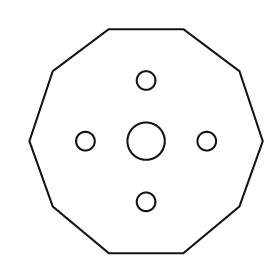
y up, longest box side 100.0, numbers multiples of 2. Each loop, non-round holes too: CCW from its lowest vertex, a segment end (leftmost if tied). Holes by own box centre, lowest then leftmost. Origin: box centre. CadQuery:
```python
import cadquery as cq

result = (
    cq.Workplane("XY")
    .moveTo(-16.0, -48.0)
    .lineTo(16.0, -48.0)
    .lineTo(40.0, -28.0)
    .lineTo(50.0, 0.0)
    .lineTo(40.0, 30.0)
    .lineTo(16.0, 48.0)
    .lineTo(-16.0, 48.0)
    .lineTo(-40.0, 30.0)
    .lineTo(-50.0, 0.0)
    .lineTo(-40.0, -28.0)
    .close()
    .moveTo(0.0, -26.0)
    .circle(4.0)
    .moveTo(-26.0, 0.0)
    .circle(4.0)
    .moveTo(0.0, 0.0)
    .circle(8.0)
    .moveTo(26.0, 0.0)
    .circle(4.0)
    .moveTo(0.0, 26.0)
    .circle(4.0)
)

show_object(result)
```